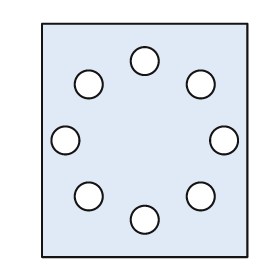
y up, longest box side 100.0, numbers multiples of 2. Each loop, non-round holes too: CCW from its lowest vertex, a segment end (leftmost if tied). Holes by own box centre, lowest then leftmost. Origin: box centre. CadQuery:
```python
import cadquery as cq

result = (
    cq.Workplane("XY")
    .moveTo(-44.0, -50.0)
    .lineTo(44.0, -50.0)
    .lineTo(44.0, 50.0)
    .lineTo(-44.0, 50.0)
    .close()
    .moveTo(0.0, -34.0)
    .circle(6.0)
    .moveTo(-24.0, -24.0)
    .circle(6.0)
    .moveTo(24.0, -24.0)
    .circle(6.0)
    .moveTo(-34.0, 0.0)
    .circle(6.0)
    .moveTo(34.0, 0.0)
    .circle(6.0)
    .moveTo(-24.0, 24.0)
    .circle(6.0)
    .moveTo(24.0, 24.0)
    .circle(6.0)
    .moveTo(0.0, 34.0)
    .circle(6.0)
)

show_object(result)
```